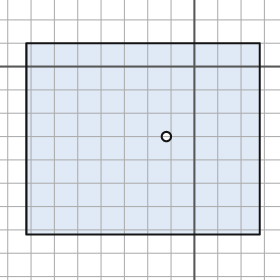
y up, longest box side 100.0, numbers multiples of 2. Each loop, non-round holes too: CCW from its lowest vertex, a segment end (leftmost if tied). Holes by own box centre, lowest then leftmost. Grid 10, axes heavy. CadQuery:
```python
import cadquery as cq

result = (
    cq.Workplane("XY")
    .moveTo(-72.0, -72.0)
    .lineTo(28.0, -72.0)
    .lineTo(28.0, 10.0)
    .lineTo(-72.0, 10.0)
    .close()
    .moveTo(-12.0, -30.0)
    .circle(2.0)
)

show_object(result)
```